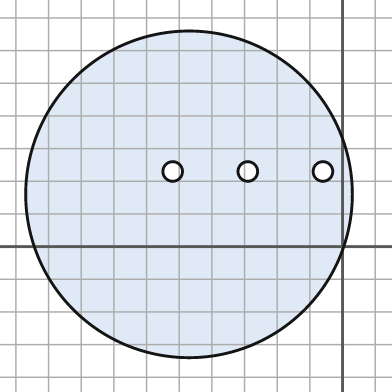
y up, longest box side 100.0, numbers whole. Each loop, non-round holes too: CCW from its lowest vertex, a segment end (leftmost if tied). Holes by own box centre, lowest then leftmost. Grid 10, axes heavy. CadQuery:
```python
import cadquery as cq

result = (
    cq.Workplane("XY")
    .moveTo(-47.0, 16.0)
    .circle(50.0)
    .moveTo(-52.0, 23.0)
    .circle(3.0)
    .moveTo(-29.0, 23.0)
    .circle(3.0)
    .moveTo(-6.0, 23.0)
    .circle(3.0)
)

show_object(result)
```